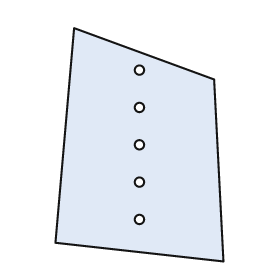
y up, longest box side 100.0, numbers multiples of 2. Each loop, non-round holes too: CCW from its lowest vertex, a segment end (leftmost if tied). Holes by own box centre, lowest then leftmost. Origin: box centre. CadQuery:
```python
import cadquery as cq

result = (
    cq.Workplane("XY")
    .moveTo(36.0, -50.0)
    .lineTo(32.0, 28.0)
    .lineTo(-28.0, 50.0)
    .lineTo(-36.0, -42.0)
    .close()
    .moveTo(0.0, -32.0)
    .circle(2.0)
    .moveTo(0.0, -16.0)
    .circle(2.0)
    .moveTo(0.0, 0.0)
    .circle(2.0)
    .moveTo(0.0, 16.0)
    .circle(2.0)
    .moveTo(0.0, 32.0)
    .circle(2.0)
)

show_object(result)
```